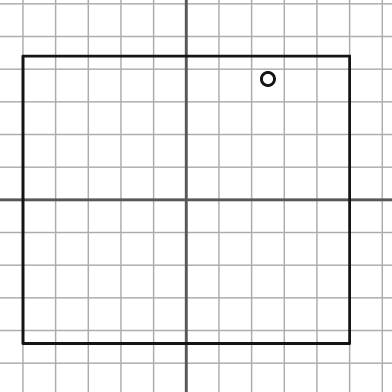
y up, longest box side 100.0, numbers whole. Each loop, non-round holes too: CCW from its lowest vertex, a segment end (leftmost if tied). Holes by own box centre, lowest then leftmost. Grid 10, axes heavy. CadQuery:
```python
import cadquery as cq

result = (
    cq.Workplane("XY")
    .moveTo(-50.0, -44.0)
    .lineTo(50.0, -44.0)
    .lineTo(50.0, 44.0)
    .lineTo(-50.0, 44.0)
    .close()
    .moveTo(25.0, 37.0)
    .circle(2.0)
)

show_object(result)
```